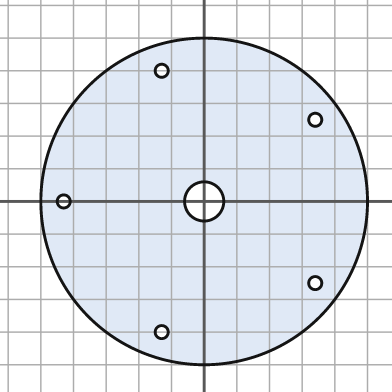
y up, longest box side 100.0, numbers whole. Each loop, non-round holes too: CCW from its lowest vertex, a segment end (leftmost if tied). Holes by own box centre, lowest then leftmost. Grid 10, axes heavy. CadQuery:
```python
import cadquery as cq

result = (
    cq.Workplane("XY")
    .moveTo(0.0, 0.0)
    .circle(50.0)
    .moveTo(-13.0, -40.0)
    .circle(2.0)
    .moveTo(34.0, -25.0)
    .circle(2.0)
    .moveTo(-43.0, 0.0)
    .circle(2.0)
    .moveTo(0.0, 0.0)
    .circle(6.0)
    .moveTo(34.0, 25.0)
    .circle(2.0)
    .moveTo(-13.0, 40.0)
    .circle(2.0)
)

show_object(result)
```